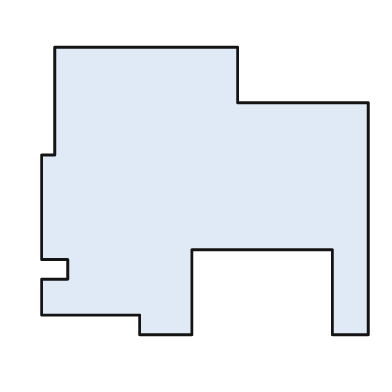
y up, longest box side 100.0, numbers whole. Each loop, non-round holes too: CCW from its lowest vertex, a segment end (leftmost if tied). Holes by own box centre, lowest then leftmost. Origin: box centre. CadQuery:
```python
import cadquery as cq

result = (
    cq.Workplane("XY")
    .moveTo(-20.0, -44.0)
    .lineTo(-4.0, -44.0)
    .lineTo(-4.0, -18.0)
    .lineTo(39.0, -18.0)
    .lineTo(39.0, -44.0)
    .lineTo(50.0, -44.0)
    .lineTo(50.0, 27.0)
    .lineTo(10.0, 27.0)
    .lineTo(10.0, 44.0)
    .lineTo(-46.0, 44.0)
    .lineTo(-46.0, 11.0)
    .lineTo(-50.0, 11.0)
    .lineTo(-50.0, -21.0)
    .lineTo(-42.0, -21.0)
    .lineTo(-42.0, -27.0)
    .lineTo(-50.0, -27.0)
    .lineTo(-50.0, -38.0)
    .lineTo(-20.0, -38.0)
    .close()
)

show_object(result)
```